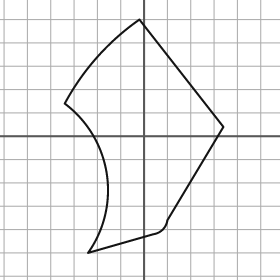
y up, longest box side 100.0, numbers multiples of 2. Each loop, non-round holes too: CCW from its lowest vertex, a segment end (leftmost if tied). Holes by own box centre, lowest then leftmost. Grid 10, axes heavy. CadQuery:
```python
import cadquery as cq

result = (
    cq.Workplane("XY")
    .moveTo(-24.0, -50.0)
    .lineTo(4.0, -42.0)
    .threePointArc((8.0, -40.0), (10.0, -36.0))
    .lineTo(34.0, 4.0)
    .lineTo(-2.0, 50.0)
    .threePointArc((-20.0, 34.0), (-34.0, 14.0))
    .threePointArc((-16.0, -16.0), (-24.0, -50.0))
    .close()
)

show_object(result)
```